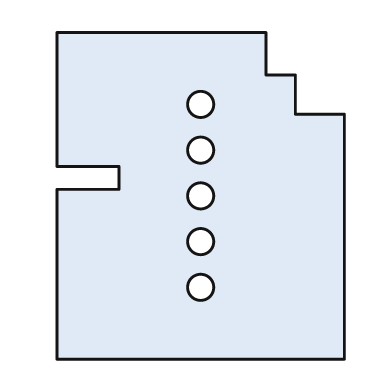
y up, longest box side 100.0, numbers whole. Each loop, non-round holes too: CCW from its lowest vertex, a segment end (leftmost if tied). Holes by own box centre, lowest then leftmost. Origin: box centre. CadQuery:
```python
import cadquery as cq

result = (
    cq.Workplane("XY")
    .moveTo(-44.0, -50.0)
    .lineTo(44.0, -50.0)
    .lineTo(44.0, 25.0)
    .lineTo(29.0, 25.0)
    .lineTo(29.0, 37.0)
    .lineTo(20.0, 37.0)
    .lineTo(20.0, 50.0)
    .lineTo(-44.0, 50.0)
    .lineTo(-44.0, 9.0)
    .lineTo(-25.0, 9.0)
    .lineTo(-25.0, 2.0)
    .lineTo(-44.0, 2.0)
    .close()
    .moveTo(0.0, -28.0)
    .circle(4.0)
    .moveTo(0.0, -14.0)
    .circle(4.0)
    .moveTo(0.0, 0.0)
    .circle(4.0)
    .moveTo(0.0, 14.0)
    .circle(4.0)
    .moveTo(0.0, 28.0)
    .circle(4.0)
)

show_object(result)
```